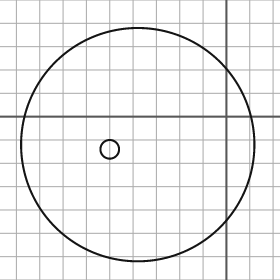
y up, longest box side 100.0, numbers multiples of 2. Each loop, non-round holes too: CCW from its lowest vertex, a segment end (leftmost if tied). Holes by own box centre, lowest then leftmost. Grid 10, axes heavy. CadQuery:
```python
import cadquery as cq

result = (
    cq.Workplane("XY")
    .moveTo(-38.0, -12.0)
    .circle(50.0)
    .moveTo(-50.0, -14.0)
    .circle(4.0)
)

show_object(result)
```